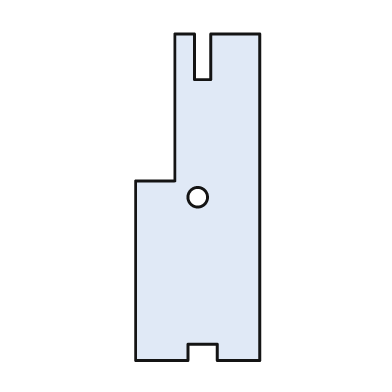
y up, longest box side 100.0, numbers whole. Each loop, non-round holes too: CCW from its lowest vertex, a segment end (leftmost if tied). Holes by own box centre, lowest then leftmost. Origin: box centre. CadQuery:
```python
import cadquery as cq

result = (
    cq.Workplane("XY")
    .moveTo(-19.0, -50.0)
    .lineTo(-3.0, -50.0)
    .lineTo(-3.0, -45.0)
    .lineTo(6.0, -45.0)
    .lineTo(6.0, -50.0)
    .lineTo(19.0, -50.0)
    .lineTo(19.0, 50.0)
    .lineTo(4.0, 50.0)
    .lineTo(4.0, 36.0)
    .lineTo(-1.0, 36.0)
    .lineTo(-1.0, 50.0)
    .lineTo(-7.0, 50.0)
    .lineTo(-7.0, 5.0)
    .lineTo(-19.0, 5.0)
    .close()
    .moveTo(0.0, 0.0)
    .circle(3.0)
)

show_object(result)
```